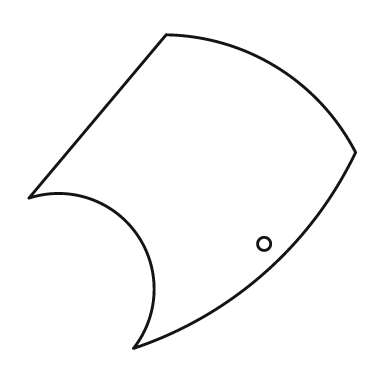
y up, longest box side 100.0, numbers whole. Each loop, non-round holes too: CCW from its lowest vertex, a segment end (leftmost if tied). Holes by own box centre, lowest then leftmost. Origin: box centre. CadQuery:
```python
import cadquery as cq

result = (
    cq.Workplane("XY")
    .moveTo(-18.0, -48.0)
    .threePointArc((22.0, -25.0), (50.0, 12.0))
    .threePointArc((26.0, 38.0), (-8.0, 48.0))
    .lineTo(-50.0, -2.0)
    .threePointArc((-17.0, -13.0), (-18.0, -48.0))
    .close()
    .moveTo(22.0, -16.0)
    .circle(2.0)
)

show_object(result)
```